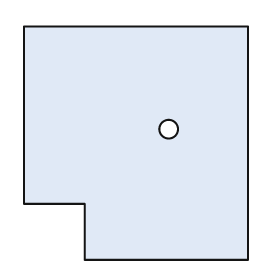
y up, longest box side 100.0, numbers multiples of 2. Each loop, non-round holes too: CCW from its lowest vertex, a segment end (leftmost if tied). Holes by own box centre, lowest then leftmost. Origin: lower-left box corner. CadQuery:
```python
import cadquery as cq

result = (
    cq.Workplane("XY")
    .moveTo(26.0, 0.0)
    .lineTo(96.0, 0.0)
    .lineTo(96.0, 100.0)
    .lineTo(0.0, 100.0)
    .lineTo(0.0, 24.0)
    .lineTo(26.0, 24.0)
    .close()
    .moveTo(62.0, 56.0)
    .circle(4.0)
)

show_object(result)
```